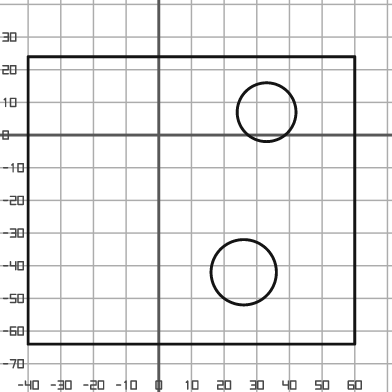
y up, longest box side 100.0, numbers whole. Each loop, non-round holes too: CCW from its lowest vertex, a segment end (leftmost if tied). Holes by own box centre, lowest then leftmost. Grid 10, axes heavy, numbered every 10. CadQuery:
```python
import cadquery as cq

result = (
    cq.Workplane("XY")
    .moveTo(-40.0, -64.0)
    .lineTo(60.0, -64.0)
    .lineTo(60.0, 24.0)
    .lineTo(-40.0, 24.0)
    .close()
    .moveTo(26.0, -42.0)
    .circle(10.0)
    .moveTo(33.0, 7.0)
    .circle(9.0)
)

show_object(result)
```